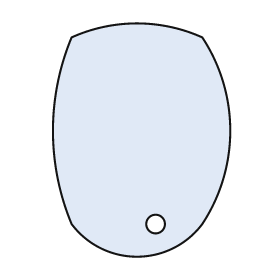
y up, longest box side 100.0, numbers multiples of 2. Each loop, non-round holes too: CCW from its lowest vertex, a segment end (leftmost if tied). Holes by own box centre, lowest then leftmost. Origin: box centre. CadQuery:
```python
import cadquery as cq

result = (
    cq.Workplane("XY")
    .moveTo(-30.0, -36.0)
    .threePointArc((-2.0, -50.0), (26.0, -36.0))
    .threePointArc((38.0, 4.0), (26.0, 44.0))
    .threePointArc((-2.0, 50.0), (-30.0, 44.0))
    .threePointArc((-38.0, 4.0), (-30.0, -36.0))
    .close()
    .moveTo(6.0, -36.0)
    .circle(4.0)
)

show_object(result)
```